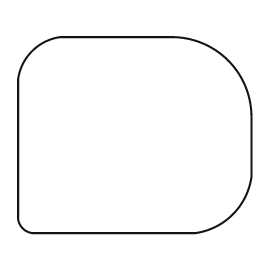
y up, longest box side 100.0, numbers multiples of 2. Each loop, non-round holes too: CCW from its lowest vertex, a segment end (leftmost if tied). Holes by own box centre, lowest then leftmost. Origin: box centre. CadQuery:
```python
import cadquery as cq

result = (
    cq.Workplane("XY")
    .moveTo(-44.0, -42.0)
    .lineTo(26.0, -42.0)
    .threePointArc((42.0, -34.0), (50.0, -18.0))
    .lineTo(50.0, 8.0)
    .threePointArc((40.0, 32.0), (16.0, 42.0))
    .lineTo(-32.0, 42.0)
    .threePointArc((-44.0, 36.0), (-50.0, 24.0))
    .lineTo(-50.0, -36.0)
    .threePointArc((-48.0, -40.0), (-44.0, -42.0))
    .close()
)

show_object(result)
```